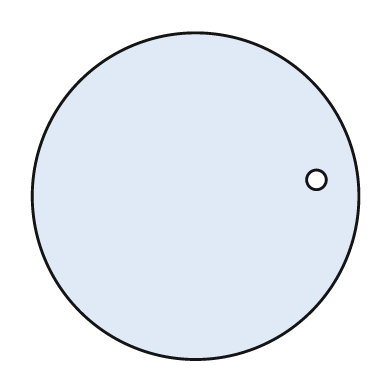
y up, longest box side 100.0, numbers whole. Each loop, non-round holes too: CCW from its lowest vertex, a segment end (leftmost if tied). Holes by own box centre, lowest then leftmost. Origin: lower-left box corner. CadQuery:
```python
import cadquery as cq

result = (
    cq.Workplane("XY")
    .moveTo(50.0, 50.0)
    .circle(50.0)
    .moveTo(87.0, 55.0)
    .circle(3.0)
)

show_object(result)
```